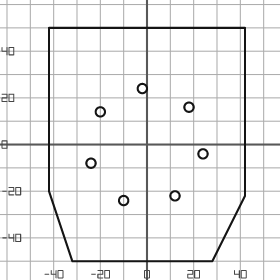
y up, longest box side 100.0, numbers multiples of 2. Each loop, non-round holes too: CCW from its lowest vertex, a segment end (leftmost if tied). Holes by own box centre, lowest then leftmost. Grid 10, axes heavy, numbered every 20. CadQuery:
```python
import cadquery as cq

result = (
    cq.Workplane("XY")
    .moveTo(-32.0, -50.0)
    .lineTo(28.0, -50.0)
    .lineTo(42.0, -22.0)
    .lineTo(42.0, 50.0)
    .lineTo(-42.0, 50.0)
    .lineTo(-42.0, -20.0)
    .close()
    .moveTo(-10.0, -24.0)
    .circle(2.0)
    .moveTo(12.0, -22.0)
    .circle(2.0)
    .moveTo(-24.0, -8.0)
    .circle(2.0)
    .moveTo(24.0, -4.0)
    .circle(2.0)
    .moveTo(-20.0, 14.0)
    .circle(2.0)
    .moveTo(18.0, 16.0)
    .circle(2.0)
    .moveTo(-2.0, 24.0)
    .circle(2.0)
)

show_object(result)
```